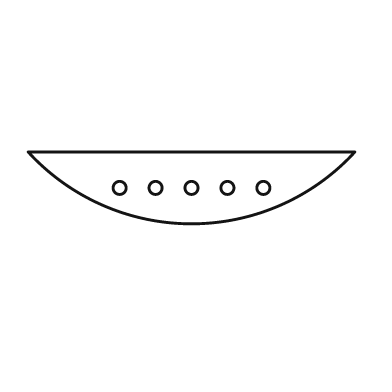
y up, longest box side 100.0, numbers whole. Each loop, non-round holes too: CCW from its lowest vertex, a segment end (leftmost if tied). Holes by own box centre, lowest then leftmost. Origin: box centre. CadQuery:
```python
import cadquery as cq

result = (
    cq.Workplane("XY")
    .moveTo(-50.0, 11.0)
    .threePointArc((0.0, -11.0), (50.0, 11.0))
    .close()
    .moveTo(-22.0, 0.0)
    .circle(2.0)
    .moveTo(-11.0, 0.0)
    .circle(2.0)
    .moveTo(0.0, 0.0)
    .circle(2.0)
    .moveTo(11.0, 0.0)
    .circle(2.0)
    .moveTo(22.0, 0.0)
    .circle(2.0)
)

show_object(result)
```